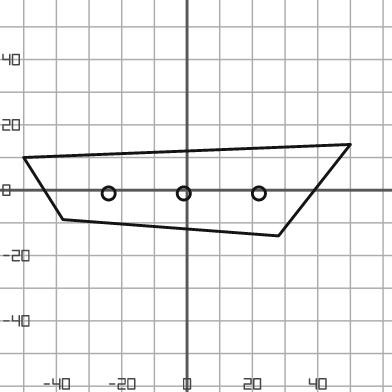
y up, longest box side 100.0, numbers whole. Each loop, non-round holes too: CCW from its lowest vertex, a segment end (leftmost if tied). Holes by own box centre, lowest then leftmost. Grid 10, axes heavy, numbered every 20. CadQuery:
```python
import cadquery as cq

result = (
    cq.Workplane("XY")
    .moveTo(28.0, -14.0)
    .lineTo(50.0, 14.0)
    .lineTo(-50.0, 10.0)
    .lineTo(-38.0, -9.0)
    .close()
    .moveTo(-24.0, -1.0)
    .circle(2.0)
    .moveTo(-1.0, -1.0)
    .circle(2.0)
    .moveTo(22.0, -1.0)
    .circle(2.0)
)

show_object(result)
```